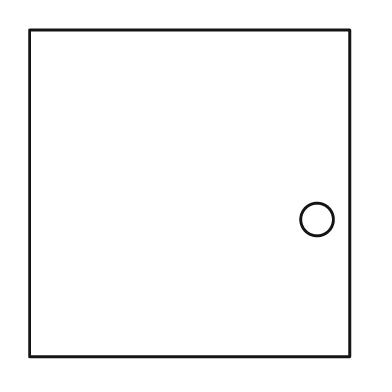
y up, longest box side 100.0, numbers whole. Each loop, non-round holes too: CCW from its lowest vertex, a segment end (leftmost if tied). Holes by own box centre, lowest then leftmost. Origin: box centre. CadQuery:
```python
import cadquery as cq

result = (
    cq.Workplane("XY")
    .moveTo(-49.0, -50.0)
    .lineTo(49.0, -50.0)
    .lineTo(49.0, 50.0)
    .lineTo(-49.0, 50.0)
    .close()
    .moveTo(39.0, -8.0)
    .circle(5.0)
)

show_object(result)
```